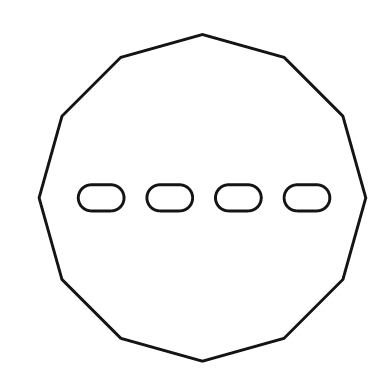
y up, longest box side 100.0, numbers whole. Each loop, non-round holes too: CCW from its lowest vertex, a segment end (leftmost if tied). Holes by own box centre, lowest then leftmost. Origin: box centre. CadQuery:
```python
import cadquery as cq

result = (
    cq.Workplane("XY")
    .moveTo(0.0, -50.0)
    .lineTo(25.0, -43.0)
    .lineTo(43.0, -25.0)
    .lineTo(50.0, 0.0)
    .lineTo(43.0, 25.0)
    .lineTo(25.0, 43.0)
    .lineTo(0.0, 50.0)
    .lineTo(-25.0, 43.0)
    .lineTo(-43.0, 25.0)
    .lineTo(-50.0, 0.0)
    .lineTo(-43.0, -25.0)
    .lineTo(-25.0, -43.0)
    .close()
    .moveTo(-34.0, -4.0)
    .lineTo(-28.0, -4.0)
    .threePointArc((-24.0, 0.0), (-28.0, 4.0))
    .lineTo(-34.0, 4.0)
    .threePointArc((-38.0, 0.0), (-34.0, -4.0))
    .close()
    .moveTo(-13.0, -4.0)
    .lineTo(-7.0, -4.0)
    .threePointArc((-3.0, 0.0), (-7.0, 4.0))
    .lineTo(-13.0, 4.0)
    .threePointArc((-17.0, 0.0), (-13.0, -4.0))
    .close()
    .moveTo(8.0, -4.0)
    .lineTo(14.0, -4.0)
    .threePointArc((18.0, 0.0), (14.0, 4.0))
    .lineTo(8.0, 4.0)
    .threePointArc((4.0, 0.0), (8.0, -4.0))
    .close()
    .moveTo(29.0, -4.0)
    .lineTo(35.0, -4.0)
    .threePointArc((39.0, 0.0), (35.0, 4.0))
    .lineTo(29.0, 4.0)
    .threePointArc((25.0, 0.0), (29.0, -4.0))
    .close()
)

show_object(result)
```